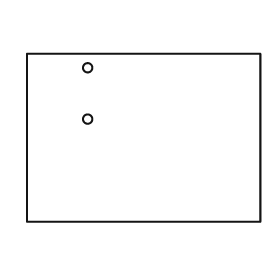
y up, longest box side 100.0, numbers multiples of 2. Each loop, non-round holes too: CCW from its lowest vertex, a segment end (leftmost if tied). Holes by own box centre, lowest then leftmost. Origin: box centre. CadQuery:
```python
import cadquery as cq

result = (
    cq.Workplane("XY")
    .moveTo(-50.0, -36.0)
    .lineTo(50.0, -36.0)
    .lineTo(50.0, 36.0)
    .lineTo(-50.0, 36.0)
    .close()
    .moveTo(-24.0, 8.0)
    .circle(2.0)
    .moveTo(-24.0, 30.0)
    .circle(2.0)
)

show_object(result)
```